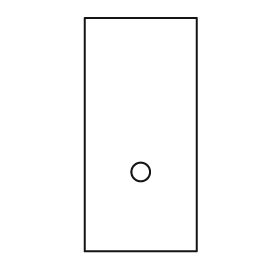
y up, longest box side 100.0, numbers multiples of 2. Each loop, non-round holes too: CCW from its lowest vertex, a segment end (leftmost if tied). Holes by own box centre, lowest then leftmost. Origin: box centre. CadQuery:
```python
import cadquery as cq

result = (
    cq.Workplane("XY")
    .moveTo(-24.0, -50.0)
    .lineTo(24.0, -50.0)
    .lineTo(24.0, 50.0)
    .lineTo(-24.0, 50.0)
    .close()
    .moveTo(0.0, -16.0)
    .circle(4.0)
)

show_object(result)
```